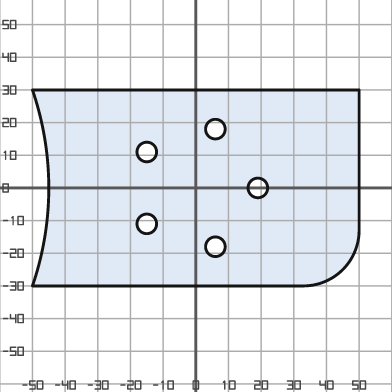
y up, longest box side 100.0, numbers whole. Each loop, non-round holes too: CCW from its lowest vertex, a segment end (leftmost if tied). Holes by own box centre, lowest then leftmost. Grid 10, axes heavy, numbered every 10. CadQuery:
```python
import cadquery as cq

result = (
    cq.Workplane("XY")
    .moveTo(-50.0, -30.0)
    .lineTo(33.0, -30.0)
    .threePointArc((45.0, -25.0), (50.0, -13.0))
    .lineTo(50.0, 30.0)
    .lineTo(-50.0, 30.0)
    .threePointArc((-45.0, 0.0), (-50.0, -30.0))
    .close()
    .moveTo(6.0, -18.0)
    .circle(3.0)
    .moveTo(-15.0, -11.0)
    .circle(3.0)
    .moveTo(19.0, 0.0)
    .circle(3.0)
    .moveTo(-15.0, 11.0)
    .circle(3.0)
    .moveTo(6.0, 18.0)
    .circle(3.0)
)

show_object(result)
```